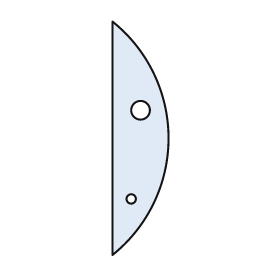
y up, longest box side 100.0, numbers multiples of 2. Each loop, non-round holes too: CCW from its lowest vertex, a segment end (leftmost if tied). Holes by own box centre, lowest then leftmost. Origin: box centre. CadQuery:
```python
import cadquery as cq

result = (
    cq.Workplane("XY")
    .moveTo(-12.0, -50.0)
    .threePointArc((12.0, 0.0), (-12.0, 50.0))
    .close()
    .moveTo(-4.0, -26.0)
    .circle(2.0)
    .moveTo(0.0, 12.0)
    .circle(4.0)
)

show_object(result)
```